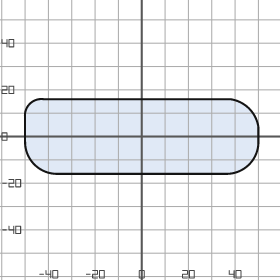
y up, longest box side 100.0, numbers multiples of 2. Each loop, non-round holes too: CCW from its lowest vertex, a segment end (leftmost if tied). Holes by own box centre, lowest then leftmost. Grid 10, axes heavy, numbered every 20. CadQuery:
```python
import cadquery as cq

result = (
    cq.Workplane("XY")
    .moveTo(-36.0, -16.0)
    .lineTo(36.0, -16.0)
    .threePointArc((46.0, -12.0), (50.0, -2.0))
    .lineTo(50.0, 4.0)
    .threePointArc((46.0, 12.0), (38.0, 16.0))
    .lineTo(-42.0, 16.0)
    .threePointArc((-48.0, 14.0), (-50.0, 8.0))
    .lineTo(-50.0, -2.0)
    .threePointArc((-46.0, -12.0), (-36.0, -16.0))
    .close()
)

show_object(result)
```